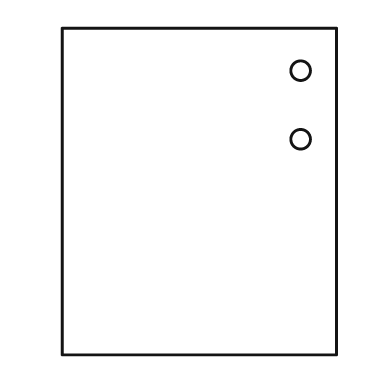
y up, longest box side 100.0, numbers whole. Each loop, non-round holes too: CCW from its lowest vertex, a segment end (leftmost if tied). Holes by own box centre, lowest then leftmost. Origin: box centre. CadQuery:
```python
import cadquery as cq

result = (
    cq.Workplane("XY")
    .moveTo(-42.0, -50.0)
    .lineTo(42.0, -50.0)
    .lineTo(42.0, 50.0)
    .lineTo(-42.0, 50.0)
    .close()
    .moveTo(31.0, 16.0)
    .circle(3.0)
    .moveTo(31.0, 37.0)
    .circle(3.0)
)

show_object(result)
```